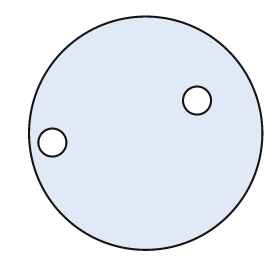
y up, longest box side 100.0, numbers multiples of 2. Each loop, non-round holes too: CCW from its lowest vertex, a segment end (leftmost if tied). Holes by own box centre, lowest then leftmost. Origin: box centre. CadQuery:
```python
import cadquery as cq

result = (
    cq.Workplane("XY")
    .moveTo(0.0, 0.0)
    .circle(50.0)
    .moveTo(-40.0, -4.0)
    .circle(6.0)
    .moveTo(22.0, 14.0)
    .circle(6.0)
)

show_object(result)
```